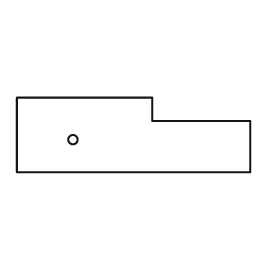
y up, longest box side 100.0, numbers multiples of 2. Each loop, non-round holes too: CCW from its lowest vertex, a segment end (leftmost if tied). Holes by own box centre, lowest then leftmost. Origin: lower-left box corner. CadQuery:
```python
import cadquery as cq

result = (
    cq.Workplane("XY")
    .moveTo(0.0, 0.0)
    .lineTo(100.0, 0.0)
    .lineTo(100.0, 22.0)
    .lineTo(58.0, 22.0)
    .lineTo(58.0, 32.0)
    .lineTo(0.0, 32.0)
    .close()
    .moveTo(24.0, 14.0)
    .circle(2.0)
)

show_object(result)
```